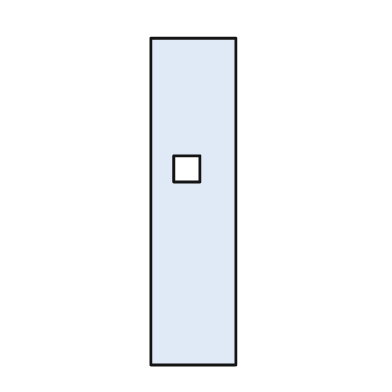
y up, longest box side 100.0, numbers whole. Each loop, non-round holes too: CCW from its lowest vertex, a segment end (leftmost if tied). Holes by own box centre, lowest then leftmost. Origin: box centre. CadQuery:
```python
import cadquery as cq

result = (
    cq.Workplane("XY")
    .moveTo(-13.0, -50.0)
    .lineTo(13.0, -50.0)
    .lineTo(13.0, 50.0)
    .lineTo(-13.0, 50.0)
    .close()
    .moveTo(-6.0, 6.0)
    .lineTo(2.0, 6.0)
    .lineTo(2.0, 14.0)
    .lineTo(-6.0, 14.0)
    .close()
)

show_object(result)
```